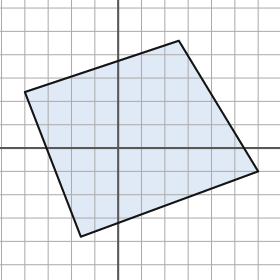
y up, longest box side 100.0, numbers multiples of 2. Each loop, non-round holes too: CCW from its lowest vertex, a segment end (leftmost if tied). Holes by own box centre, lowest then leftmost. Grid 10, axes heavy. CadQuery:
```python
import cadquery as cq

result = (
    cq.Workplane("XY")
    .moveTo(-16.0, -38.0)
    .lineTo(60.0, -10.0)
    .lineTo(26.0, 46.0)
    .lineTo(-40.0, 24.0)
    .close()
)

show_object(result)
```